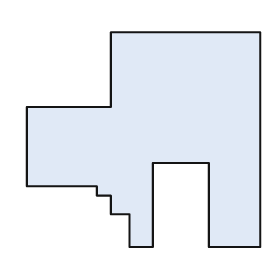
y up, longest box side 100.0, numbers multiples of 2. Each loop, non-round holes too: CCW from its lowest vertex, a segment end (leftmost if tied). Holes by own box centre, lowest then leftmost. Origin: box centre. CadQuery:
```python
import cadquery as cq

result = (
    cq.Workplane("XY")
    .moveTo(-6.0, -46.0)
    .lineTo(4.0, -46.0)
    .lineTo(4.0, -10.0)
    .lineTo(28.0, -10.0)
    .lineTo(28.0, -46.0)
    .lineTo(50.0, -46.0)
    .lineTo(50.0, 46.0)
    .lineTo(-14.0, 46.0)
    .lineTo(-14.0, 14.0)
    .lineTo(-50.0, 14.0)
    .lineTo(-50.0, -20.0)
    .lineTo(-20.0, -20.0)
    .lineTo(-20.0, -24.0)
    .lineTo(-14.0, -24.0)
    .lineTo(-14.0, -32.0)
    .lineTo(-6.0, -32.0)
    .close()
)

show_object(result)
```